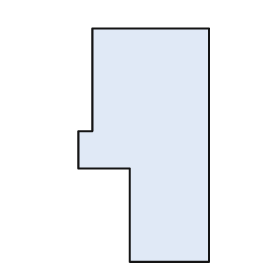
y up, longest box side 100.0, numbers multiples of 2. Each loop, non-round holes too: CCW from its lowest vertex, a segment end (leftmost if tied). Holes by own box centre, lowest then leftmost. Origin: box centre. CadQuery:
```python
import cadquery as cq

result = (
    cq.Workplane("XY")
    .moveTo(-6.0, -50.0)
    .lineTo(28.0, -50.0)
    .lineTo(28.0, 50.0)
    .lineTo(-22.0, 50.0)
    .lineTo(-22.0, 6.0)
    .lineTo(-28.0, 6.0)
    .lineTo(-28.0, -10.0)
    .lineTo(-6.0, -10.0)
    .close()
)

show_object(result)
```